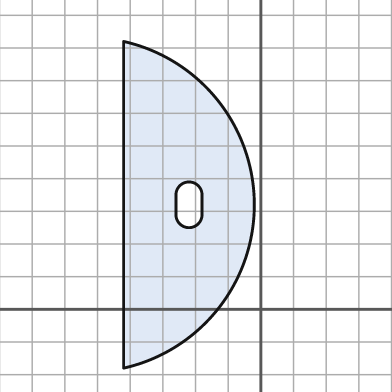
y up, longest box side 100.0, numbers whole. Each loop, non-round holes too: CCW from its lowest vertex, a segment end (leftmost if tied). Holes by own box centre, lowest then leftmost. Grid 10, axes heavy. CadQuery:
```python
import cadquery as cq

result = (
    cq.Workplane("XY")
    .moveTo(-42.0, -18.0)
    .threePointArc((-2.0, 32.0), (-42.0, 82.0))
    .close()
    .moveTo(-26.0, 29.0)
    .threePointArc((-22.0, 25.0), (-18.0, 29.0))
    .lineTo(-18.0, 35.0)
    .threePointArc((-22.0, 39.0), (-26.0, 35.0))
    .close()
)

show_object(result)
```